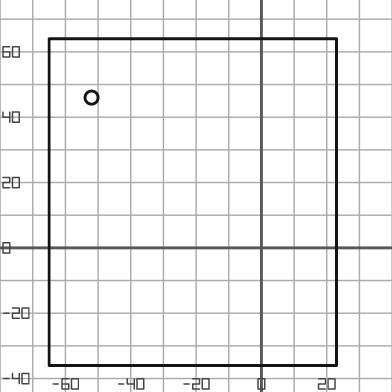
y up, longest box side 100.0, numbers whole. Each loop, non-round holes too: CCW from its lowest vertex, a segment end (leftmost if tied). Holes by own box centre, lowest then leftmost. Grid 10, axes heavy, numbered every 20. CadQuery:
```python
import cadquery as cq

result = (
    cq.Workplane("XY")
    .moveTo(-65.0, -36.0)
    .lineTo(23.0, -36.0)
    .lineTo(23.0, 64.0)
    .lineTo(-65.0, 64.0)
    .close()
    .moveTo(-52.0, 46.0)
    .circle(2.0)
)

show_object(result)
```